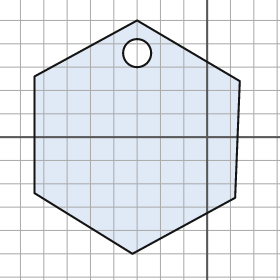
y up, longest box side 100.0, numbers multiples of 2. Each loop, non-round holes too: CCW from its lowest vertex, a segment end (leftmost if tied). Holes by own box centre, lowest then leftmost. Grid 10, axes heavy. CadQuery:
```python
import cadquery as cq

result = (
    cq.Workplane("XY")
    .moveTo(-32.0, -50.0)
    .lineTo(12.0, -26.0)
    .lineTo(14.0, 24.0)
    .lineTo(-30.0, 50.0)
    .lineTo(-74.0, 26.0)
    .lineTo(-74.0, -24.0)
    .close()
    .moveTo(-30.0, 36.0)
    .circle(6.0)
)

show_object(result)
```